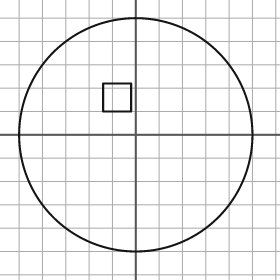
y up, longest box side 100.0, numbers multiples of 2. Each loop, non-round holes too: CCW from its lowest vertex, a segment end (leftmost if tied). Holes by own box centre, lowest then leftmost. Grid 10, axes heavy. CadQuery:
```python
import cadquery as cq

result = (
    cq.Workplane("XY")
    .moveTo(0.0, 0.0)
    .circle(50.0)
    .moveTo(-14.0, 10.0)
    .lineTo(-2.0, 10.0)
    .lineTo(-2.0, 22.0)
    .lineTo(-14.0, 22.0)
    .close()
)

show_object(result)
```